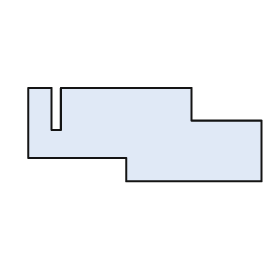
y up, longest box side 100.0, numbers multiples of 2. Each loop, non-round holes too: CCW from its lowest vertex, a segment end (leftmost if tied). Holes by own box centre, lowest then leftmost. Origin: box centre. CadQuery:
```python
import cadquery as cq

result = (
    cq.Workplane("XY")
    .moveTo(-8.0, -20.0)
    .lineTo(50.0, -20.0)
    .lineTo(50.0, 6.0)
    .lineTo(20.0, 6.0)
    .lineTo(20.0, 20.0)
    .lineTo(-36.0, 20.0)
    .lineTo(-36.0, 2.0)
    .lineTo(-40.0, 2.0)
    .lineTo(-40.0, 20.0)
    .lineTo(-50.0, 20.0)
    .lineTo(-50.0, -10.0)
    .lineTo(-8.0, -10.0)
    .close()
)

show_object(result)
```